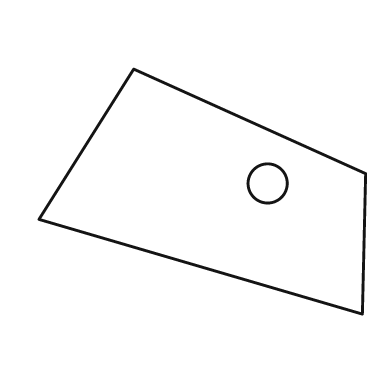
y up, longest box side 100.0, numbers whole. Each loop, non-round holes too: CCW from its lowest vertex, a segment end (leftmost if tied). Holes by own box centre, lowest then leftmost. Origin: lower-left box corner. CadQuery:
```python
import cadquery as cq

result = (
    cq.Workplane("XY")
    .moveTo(99.0, 0.0)
    .lineTo(100.0, 43.0)
    .lineTo(29.0, 75.0)
    .lineTo(0.0, 29.0)
    .close()
    .moveTo(70.0, 40.0)
    .circle(6.0)
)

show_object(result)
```